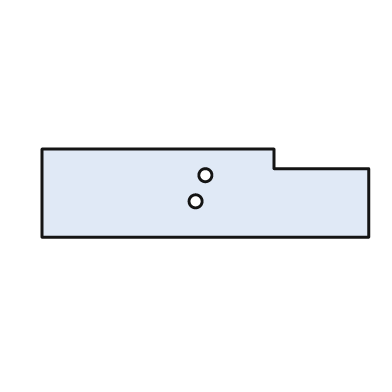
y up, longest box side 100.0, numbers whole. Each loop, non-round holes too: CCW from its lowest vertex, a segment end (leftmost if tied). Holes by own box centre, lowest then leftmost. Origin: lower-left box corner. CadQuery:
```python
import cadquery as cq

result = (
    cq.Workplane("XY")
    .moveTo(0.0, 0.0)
    .lineTo(100.0, 0.0)
    .lineTo(100.0, 21.0)
    .lineTo(71.0, 21.0)
    .lineTo(71.0, 27.0)
    .lineTo(0.0, 27.0)
    .close()
    .moveTo(47.0, 11.0)
    .circle(2.0)
    .moveTo(50.0, 19.0)
    .circle(2.0)
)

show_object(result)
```